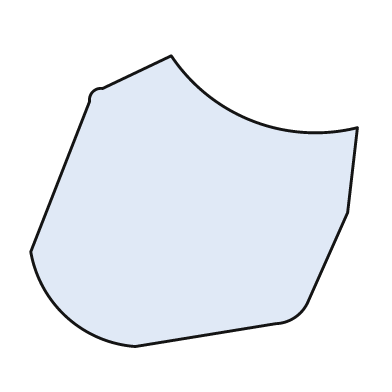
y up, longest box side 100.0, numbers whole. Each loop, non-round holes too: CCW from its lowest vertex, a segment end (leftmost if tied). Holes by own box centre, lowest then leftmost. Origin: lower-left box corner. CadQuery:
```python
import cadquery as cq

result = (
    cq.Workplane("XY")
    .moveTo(32.0, 0.0)
    .lineTo(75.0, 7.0)
    .threePointArc((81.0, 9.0), (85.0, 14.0))
    .lineTo(97.0, 41.0)
    .lineTo(100.0, 67.0)
    .threePointArc((68.0, 69.0), (43.0, 89.0))
    .lineTo(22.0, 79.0)
    .threePointArc((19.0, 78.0), (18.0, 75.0))
    .lineTo(0.0, 29.0)
    .threePointArc((11.0, 9.0), (32.0, 0.0))
    .close()
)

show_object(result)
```